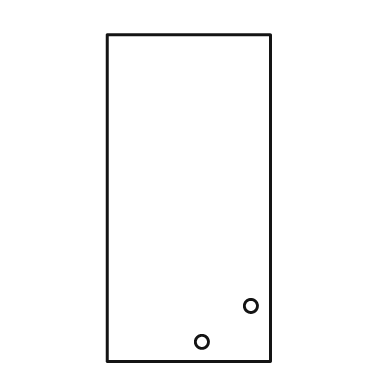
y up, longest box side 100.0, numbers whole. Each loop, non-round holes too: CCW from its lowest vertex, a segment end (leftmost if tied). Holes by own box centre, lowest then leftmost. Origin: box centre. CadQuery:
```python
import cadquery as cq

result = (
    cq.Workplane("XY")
    .moveTo(-25.0, -50.0)
    .lineTo(25.0, -50.0)
    .lineTo(25.0, 50.0)
    .lineTo(-25.0, 50.0)
    .close()
    .moveTo(4.0, -44.0)
    .circle(2.0)
    .moveTo(19.0, -33.0)
    .circle(2.0)
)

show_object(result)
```